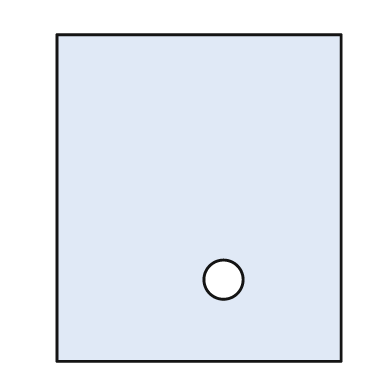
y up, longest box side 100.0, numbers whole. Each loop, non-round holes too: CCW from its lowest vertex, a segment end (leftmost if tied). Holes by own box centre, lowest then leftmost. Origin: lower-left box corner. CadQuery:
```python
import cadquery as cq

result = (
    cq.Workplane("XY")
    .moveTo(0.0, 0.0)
    .lineTo(87.0, 0.0)
    .lineTo(87.0, 100.0)
    .lineTo(0.0, 100.0)
    .close()
    .moveTo(51.0, 25.0)
    .circle(6.0)
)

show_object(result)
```